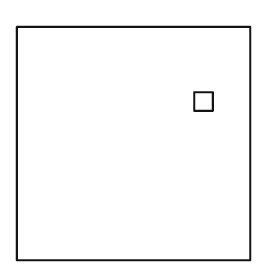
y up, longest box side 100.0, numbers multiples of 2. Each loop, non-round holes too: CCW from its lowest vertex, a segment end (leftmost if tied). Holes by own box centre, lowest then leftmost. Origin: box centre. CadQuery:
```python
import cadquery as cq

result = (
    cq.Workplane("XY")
    .moveTo(-50.0, -50.0)
    .lineTo(50.0, -50.0)
    .lineTo(50.0, 50.0)
    .lineTo(-50.0, 50.0)
    .close()
    .moveTo(26.0, 14.0)
    .lineTo(34.0, 14.0)
    .lineTo(34.0, 22.0)
    .lineTo(26.0, 22.0)
    .close()
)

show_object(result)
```